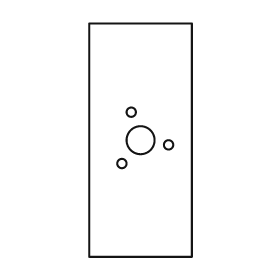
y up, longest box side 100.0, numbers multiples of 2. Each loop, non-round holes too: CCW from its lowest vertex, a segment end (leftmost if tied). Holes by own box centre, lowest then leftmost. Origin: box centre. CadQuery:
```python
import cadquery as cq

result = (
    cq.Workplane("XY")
    .moveTo(-22.0, -50.0)
    .lineTo(22.0, -50.0)
    .lineTo(22.0, 50.0)
    .lineTo(-22.0, 50.0)
    .close()
    .moveTo(-8.0, -10.0)
    .circle(2.0)
    .moveTo(12.0, -2.0)
    .circle(2.0)
    .moveTo(0.0, 0.0)
    .circle(6.0)
    .moveTo(-4.0, 12.0)
    .circle(2.0)
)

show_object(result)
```